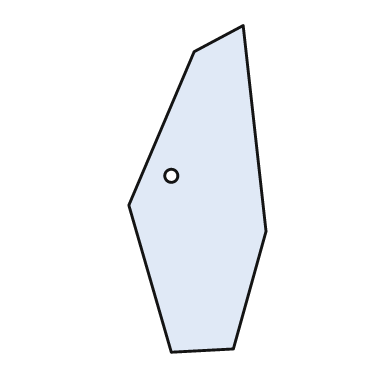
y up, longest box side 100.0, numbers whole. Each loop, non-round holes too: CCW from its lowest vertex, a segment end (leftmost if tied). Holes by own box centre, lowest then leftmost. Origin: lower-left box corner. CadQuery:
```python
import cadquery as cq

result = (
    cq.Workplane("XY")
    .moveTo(13.0, 0.0)
    .lineTo(32.0, 1.0)
    .lineTo(42.0, 37.0)
    .lineTo(35.0, 100.0)
    .lineTo(20.0, 92.0)
    .lineTo(0.0, 45.0)
    .close()
    .moveTo(13.0, 54.0)
    .circle(2.0)
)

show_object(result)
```